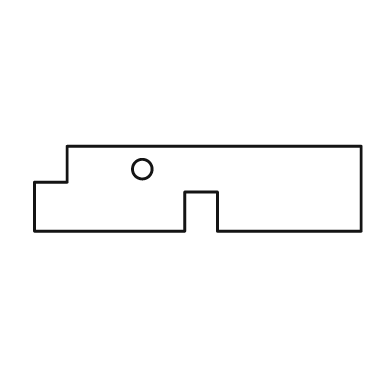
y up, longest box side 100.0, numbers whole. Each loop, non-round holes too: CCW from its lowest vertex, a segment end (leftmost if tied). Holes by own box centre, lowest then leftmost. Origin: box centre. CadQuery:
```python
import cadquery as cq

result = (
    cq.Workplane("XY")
    .moveTo(-50.0, -13.0)
    .lineTo(-4.0, -13.0)
    .lineTo(-4.0, -1.0)
    .lineTo(6.0, -1.0)
    .lineTo(6.0, -13.0)
    .lineTo(50.0, -13.0)
    .lineTo(50.0, 13.0)
    .lineTo(-40.0, 13.0)
    .lineTo(-40.0, 2.0)
    .lineTo(-50.0, 2.0)
    .close()
    .moveTo(-17.0, 6.0)
    .circle(3.0)
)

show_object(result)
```